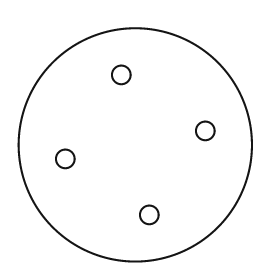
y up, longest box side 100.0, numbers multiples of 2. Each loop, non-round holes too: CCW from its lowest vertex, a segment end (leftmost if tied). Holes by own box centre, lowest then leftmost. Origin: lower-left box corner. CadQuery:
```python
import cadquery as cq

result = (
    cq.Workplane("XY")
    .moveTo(50.0, 50.0)
    .circle(50.0)
    .moveTo(56.0, 20.0)
    .circle(4.0)
    .moveTo(20.0, 44.0)
    .circle(4.0)
    .moveTo(80.0, 56.0)
    .circle(4.0)
    .moveTo(44.0, 80.0)
    .circle(4.0)
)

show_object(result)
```